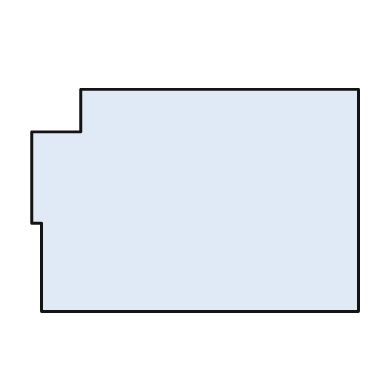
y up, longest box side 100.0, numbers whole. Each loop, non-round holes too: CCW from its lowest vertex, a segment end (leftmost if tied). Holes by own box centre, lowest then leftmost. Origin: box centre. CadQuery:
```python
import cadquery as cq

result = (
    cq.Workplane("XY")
    .moveTo(-47.0, -34.0)
    .lineTo(50.0, -34.0)
    .lineTo(50.0, 34.0)
    .lineTo(-35.0, 34.0)
    .lineTo(-35.0, 21.0)
    .lineTo(-50.0, 21.0)
    .lineTo(-50.0, -7.0)
    .lineTo(-47.0, -7.0)
    .close()
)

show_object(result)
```